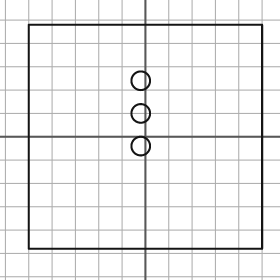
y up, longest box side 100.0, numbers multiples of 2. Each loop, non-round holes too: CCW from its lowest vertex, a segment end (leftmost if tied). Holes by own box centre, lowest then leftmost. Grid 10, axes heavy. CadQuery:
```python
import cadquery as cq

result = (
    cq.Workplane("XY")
    .moveTo(-50.0, -48.0)
    .lineTo(50.0, -48.0)
    .lineTo(50.0, 48.0)
    .lineTo(-50.0, 48.0)
    .close()
    .moveTo(-2.0, -4.0)
    .circle(4.0)
    .moveTo(-2.0, 10.0)
    .circle(4.0)
    .moveTo(-2.0, 24.0)
    .circle(4.0)
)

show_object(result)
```